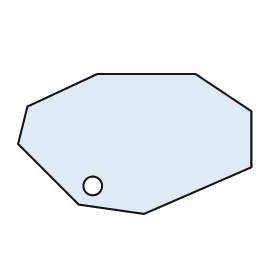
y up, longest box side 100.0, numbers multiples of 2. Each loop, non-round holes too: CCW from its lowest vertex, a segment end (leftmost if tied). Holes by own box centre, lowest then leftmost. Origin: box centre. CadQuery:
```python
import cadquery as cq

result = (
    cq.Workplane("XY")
    .moveTo(4.0, -30.0)
    .lineTo(50.0, -10.0)
    .lineTo(50.0, 14.0)
    .lineTo(26.0, 30.0)
    .lineTo(-16.0, 30.0)
    .lineTo(-46.0, 16.0)
    .lineTo(-50.0, 0.0)
    .lineTo(-24.0, -26.0)
    .close()
    .moveTo(-18.0, -18.0)
    .circle(4.0)
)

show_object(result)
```